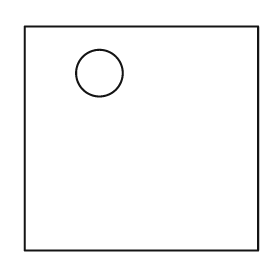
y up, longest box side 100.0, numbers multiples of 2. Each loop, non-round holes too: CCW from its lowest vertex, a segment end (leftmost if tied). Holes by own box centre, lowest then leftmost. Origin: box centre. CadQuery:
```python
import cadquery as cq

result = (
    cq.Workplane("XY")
    .moveTo(-50.0, -48.0)
    .lineTo(50.0, -48.0)
    .lineTo(50.0, 48.0)
    .lineTo(-50.0, 48.0)
    .close()
    .moveTo(-18.0, 28.0)
    .circle(10.0)
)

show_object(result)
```